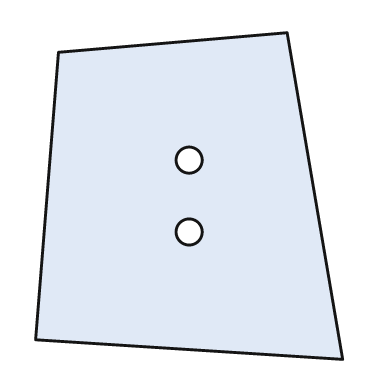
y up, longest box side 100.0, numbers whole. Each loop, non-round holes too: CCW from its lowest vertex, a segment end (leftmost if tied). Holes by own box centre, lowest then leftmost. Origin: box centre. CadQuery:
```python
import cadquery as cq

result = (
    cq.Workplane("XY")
    .moveTo(47.0, -50.0)
    .lineTo(30.0, 50.0)
    .lineTo(-40.0, 44.0)
    .lineTo(-47.0, -44.0)
    .close()
    .moveTo(0.0, -11.0)
    .circle(4.0)
    .moveTo(0.0, 11.0)
    .circle(4.0)
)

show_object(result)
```